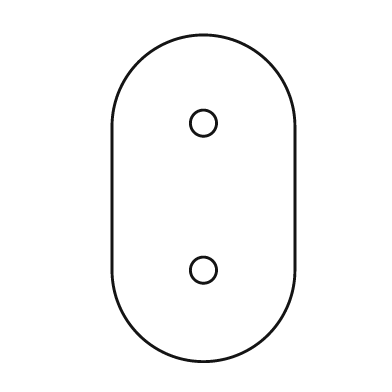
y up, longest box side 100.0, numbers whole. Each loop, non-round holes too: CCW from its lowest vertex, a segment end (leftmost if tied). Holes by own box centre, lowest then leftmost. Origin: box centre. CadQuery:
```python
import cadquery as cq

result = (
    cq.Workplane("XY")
    .moveTo(-28.0, -22.0)
    .threePointArc((0.0, -50.0), (28.0, -22.0))
    .lineTo(28.0, 22.0)
    .threePointArc((0.0, 50.0), (-28.0, 22.0))
    .close()
    .moveTo(0.0, -22.0)
    .circle(4.0)
    .moveTo(0.0, 23.0)
    .circle(4.0)
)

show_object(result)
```